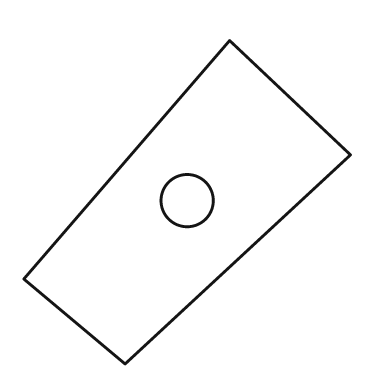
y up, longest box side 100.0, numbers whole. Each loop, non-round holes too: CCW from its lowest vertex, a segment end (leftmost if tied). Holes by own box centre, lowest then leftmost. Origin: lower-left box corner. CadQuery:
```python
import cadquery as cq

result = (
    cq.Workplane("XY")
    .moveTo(31.0, 0.0)
    .lineTo(100.0, 64.0)
    .lineTo(63.0, 99.0)
    .lineTo(0.0, 26.0)
    .close()
    .moveTo(50.0, 50.0)
    .circle(8.0)
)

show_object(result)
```